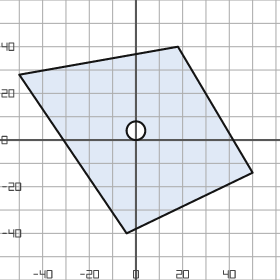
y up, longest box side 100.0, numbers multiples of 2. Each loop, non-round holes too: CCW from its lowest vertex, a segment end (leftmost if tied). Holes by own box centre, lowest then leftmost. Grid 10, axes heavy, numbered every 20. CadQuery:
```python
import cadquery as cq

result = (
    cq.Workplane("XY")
    .moveTo(-4.0, -40.0)
    .lineTo(50.0, -14.0)
    .lineTo(18.0, 40.0)
    .lineTo(-50.0, 28.0)
    .close()
    .moveTo(0.0, 4.0)
    .circle(4.0)
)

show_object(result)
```